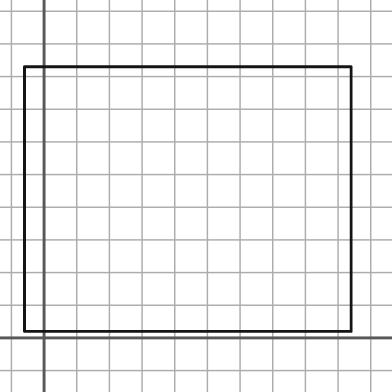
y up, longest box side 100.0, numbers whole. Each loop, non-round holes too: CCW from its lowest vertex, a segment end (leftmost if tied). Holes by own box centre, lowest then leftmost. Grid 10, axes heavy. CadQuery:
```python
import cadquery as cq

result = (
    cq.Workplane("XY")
    .moveTo(-6.0, 2.0)
    .lineTo(94.0, 2.0)
    .lineTo(94.0, 83.0)
    .lineTo(-6.0, 83.0)
    .close()
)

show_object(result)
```